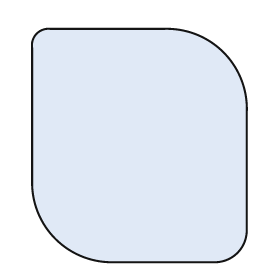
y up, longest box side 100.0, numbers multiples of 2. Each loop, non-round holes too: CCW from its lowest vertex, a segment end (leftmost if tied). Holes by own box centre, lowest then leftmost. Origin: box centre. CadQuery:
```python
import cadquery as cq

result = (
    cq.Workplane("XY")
    .moveTo(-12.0, -50.0)
    .lineTo(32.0, -50.0)
    .threePointArc((42.0, -46.0), (46.0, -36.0))
    .lineTo(46.0, 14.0)
    .threePointArc((36.0, 40.0), (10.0, 50.0))
    .lineTo(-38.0, 50.0)
    .threePointArc((-44.0, 48.0), (-46.0, 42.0))
    .lineTo(-46.0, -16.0)
    .threePointArc((-36.0, -40.0), (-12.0, -50.0))
    .close()
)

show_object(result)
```